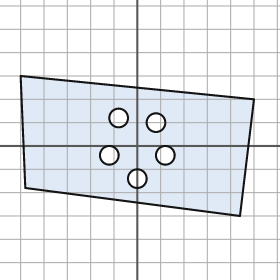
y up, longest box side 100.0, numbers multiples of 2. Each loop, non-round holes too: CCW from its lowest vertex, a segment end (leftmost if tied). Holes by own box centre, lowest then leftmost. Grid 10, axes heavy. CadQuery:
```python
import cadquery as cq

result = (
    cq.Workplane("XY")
    .moveTo(44.0, -30.0)
    .lineTo(50.0, 20.0)
    .lineTo(-50.0, 30.0)
    .lineTo(-48.0, -18.0)
    .close()
    .moveTo(0.0, -14.0)
    .circle(4.0)
    .moveTo(-12.0, -4.0)
    .circle(4.0)
    .moveTo(12.0, -4.0)
    .circle(4.0)
    .moveTo(8.0, 10.0)
    .circle(4.0)
    .moveTo(-8.0, 12.0)
    .circle(4.0)
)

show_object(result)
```